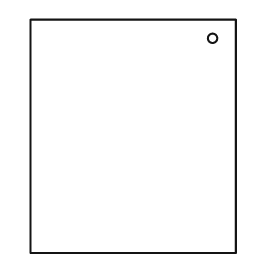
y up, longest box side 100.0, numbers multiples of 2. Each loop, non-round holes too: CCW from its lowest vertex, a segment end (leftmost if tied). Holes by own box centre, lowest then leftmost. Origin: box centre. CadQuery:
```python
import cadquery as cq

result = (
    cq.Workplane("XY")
    .moveTo(-44.0, -50.0)
    .lineTo(44.0, -50.0)
    .lineTo(44.0, 50.0)
    .lineTo(-44.0, 50.0)
    .close()
    .moveTo(34.0, 42.0)
    .circle(2.0)
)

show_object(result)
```